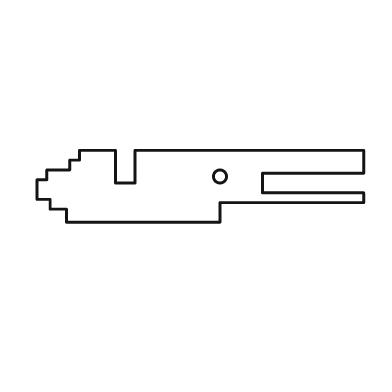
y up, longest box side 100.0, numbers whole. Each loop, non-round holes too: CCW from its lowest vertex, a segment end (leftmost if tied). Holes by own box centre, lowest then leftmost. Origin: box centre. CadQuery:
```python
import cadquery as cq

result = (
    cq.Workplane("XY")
    .moveTo(-41.0, -11.0)
    .lineTo(6.0, -11.0)
    .lineTo(6.0, -5.0)
    .lineTo(50.0, -5.0)
    .lineTo(50.0, -2.0)
    .lineTo(19.0, -2.0)
    .lineTo(19.0, 4.0)
    .lineTo(50.0, 4.0)
    .lineTo(50.0, 11.0)
    .lineTo(-20.0, 11.0)
    .lineTo(-20.0, 1.0)
    .lineTo(-26.0, 1.0)
    .lineTo(-26.0, 11.0)
    .lineTo(-37.0, 11.0)
    .lineTo(-37.0, 8.0)
    .lineTo(-40.0, 8.0)
    .lineTo(-40.0, 5.0)
    .lineTo(-47.0, 5.0)
    .lineTo(-47.0, 2.0)
    .lineTo(-50.0, 2.0)
    .lineTo(-50.0, -4.0)
    .lineTo(-46.0, -4.0)
    .lineTo(-46.0, -7.0)
    .lineTo(-41.0, -7.0)
    .close()
    .moveTo(6.0, 3.0)
    .circle(2.0)
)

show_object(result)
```